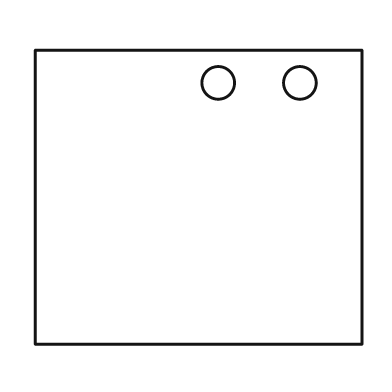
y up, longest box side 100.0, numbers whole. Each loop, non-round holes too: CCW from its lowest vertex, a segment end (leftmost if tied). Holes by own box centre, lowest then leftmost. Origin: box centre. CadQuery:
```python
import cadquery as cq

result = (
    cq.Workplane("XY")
    .moveTo(-50.0, -45.0)
    .lineTo(50.0, -45.0)
    .lineTo(50.0, 45.0)
    .lineTo(-50.0, 45.0)
    .close()
    .moveTo(6.0, 35.0)
    .circle(5.0)
    .moveTo(31.0, 35.0)
    .circle(5.0)
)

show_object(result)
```